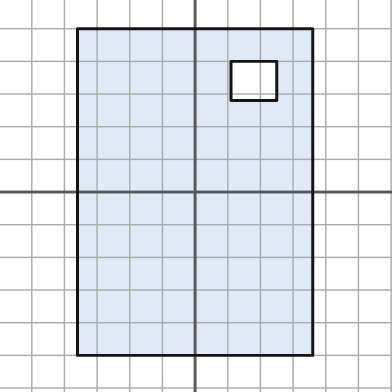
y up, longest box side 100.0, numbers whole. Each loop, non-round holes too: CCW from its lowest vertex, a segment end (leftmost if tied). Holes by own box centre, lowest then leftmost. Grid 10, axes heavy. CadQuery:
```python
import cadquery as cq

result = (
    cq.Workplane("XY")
    .moveTo(-36.0, -50.0)
    .lineTo(36.0, -50.0)
    .lineTo(36.0, 50.0)
    .lineTo(-36.0, 50.0)
    .close()
    .moveTo(11.0, 28.0)
    .lineTo(25.0, 28.0)
    .lineTo(25.0, 40.0)
    .lineTo(11.0, 40.0)
    .close()
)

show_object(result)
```